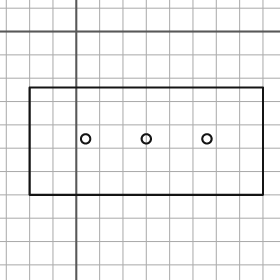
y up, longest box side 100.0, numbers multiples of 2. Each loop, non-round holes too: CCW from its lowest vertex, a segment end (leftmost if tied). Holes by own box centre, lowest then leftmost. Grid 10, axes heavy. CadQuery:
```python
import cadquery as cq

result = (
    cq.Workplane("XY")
    .moveTo(-20.0, -70.0)
    .lineTo(80.0, -70.0)
    .lineTo(80.0, -24.0)
    .lineTo(-20.0, -24.0)
    .close()
    .moveTo(4.0, -46.0)
    .circle(2.0)
    .moveTo(30.0, -46.0)
    .circle(2.0)
    .moveTo(56.0, -46.0)
    .circle(2.0)
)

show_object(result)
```